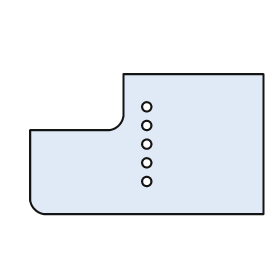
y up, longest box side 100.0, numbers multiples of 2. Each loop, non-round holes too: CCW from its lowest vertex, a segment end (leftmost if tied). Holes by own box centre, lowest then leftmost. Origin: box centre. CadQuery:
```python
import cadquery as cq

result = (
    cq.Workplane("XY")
    .moveTo(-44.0, -30.0)
    .lineTo(50.0, -30.0)
    .lineTo(50.0, 30.0)
    .lineTo(-10.0, 30.0)
    .lineTo(-10.0, 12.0)
    .threePointArc((-12.0, 8.0), (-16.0, 6.0))
    .lineTo(-50.0, 6.0)
    .lineTo(-50.0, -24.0)
    .threePointArc((-48.0, -28.0), (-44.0, -30.0))
    .close()
    .moveTo(0.0, -16.0)
    .circle(2.0)
    .moveTo(0.0, -8.0)
    .circle(2.0)
    .moveTo(0.0, 0.0)
    .circle(2.0)
    .moveTo(0.0, 8.0)
    .circle(2.0)
    .moveTo(0.0, 16.0)
    .circle(2.0)
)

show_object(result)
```